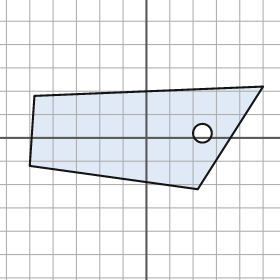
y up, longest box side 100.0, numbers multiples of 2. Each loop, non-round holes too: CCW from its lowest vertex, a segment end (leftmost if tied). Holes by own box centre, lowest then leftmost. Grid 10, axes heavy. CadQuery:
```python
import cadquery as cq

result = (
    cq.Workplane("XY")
    .moveTo(22.0, -22.0)
    .lineTo(50.0, 22.0)
    .lineTo(-48.0, 18.0)
    .lineTo(-50.0, -12.0)
    .close()
    .moveTo(24.0, 2.0)
    .circle(4.0)
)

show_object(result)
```